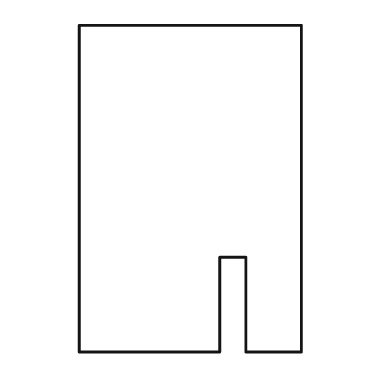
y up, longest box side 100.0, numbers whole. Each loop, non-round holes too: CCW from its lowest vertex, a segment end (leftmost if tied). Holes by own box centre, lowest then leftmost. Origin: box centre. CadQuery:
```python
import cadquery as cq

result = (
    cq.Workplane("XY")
    .moveTo(-34.0, -50.0)
    .lineTo(9.0, -50.0)
    .lineTo(9.0, -21.0)
    .lineTo(17.0, -21.0)
    .lineTo(17.0, -50.0)
    .lineTo(34.0, -50.0)
    .lineTo(34.0, 50.0)
    .lineTo(-34.0, 50.0)
    .close()
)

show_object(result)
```